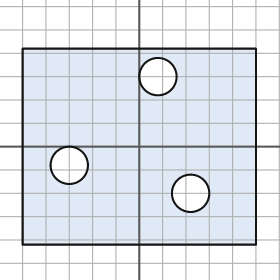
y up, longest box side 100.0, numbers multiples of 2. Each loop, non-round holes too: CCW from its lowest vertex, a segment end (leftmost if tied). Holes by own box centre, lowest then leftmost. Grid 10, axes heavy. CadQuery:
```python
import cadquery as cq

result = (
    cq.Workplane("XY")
    .moveTo(-50.0, -42.0)
    .lineTo(50.0, -42.0)
    .lineTo(50.0, 42.0)
    .lineTo(-50.0, 42.0)
    .close()
    .moveTo(22.0, -20.0)
    .circle(8.0)
    .moveTo(-30.0, -8.0)
    .circle(8.0)
    .moveTo(8.0, 30.0)
    .circle(8.0)
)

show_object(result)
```